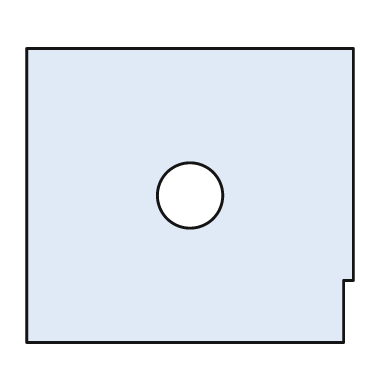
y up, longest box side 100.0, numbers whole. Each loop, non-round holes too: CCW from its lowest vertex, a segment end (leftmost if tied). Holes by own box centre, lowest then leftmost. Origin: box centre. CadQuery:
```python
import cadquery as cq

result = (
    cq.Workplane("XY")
    .moveTo(-50.0, -45.0)
    .lineTo(47.0, -45.0)
    .lineTo(47.0, -26.0)
    .lineTo(50.0, -26.0)
    .lineTo(50.0, 45.0)
    .lineTo(-50.0, 45.0)
    .close()
    .moveTo(0.0, 0.0)
    .circle(10.0)
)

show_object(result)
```